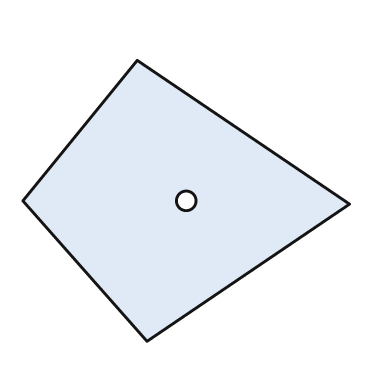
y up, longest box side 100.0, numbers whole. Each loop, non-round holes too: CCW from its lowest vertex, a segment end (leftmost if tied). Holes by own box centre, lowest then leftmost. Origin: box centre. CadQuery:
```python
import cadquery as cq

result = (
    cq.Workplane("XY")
    .moveTo(-12.0, -43.0)
    .lineTo(50.0, -1.0)
    .lineTo(-15.0, 43.0)
    .lineTo(-50.0, 0.0)
    .close()
    .moveTo(0.0, 0.0)
    .circle(3.0)
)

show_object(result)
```